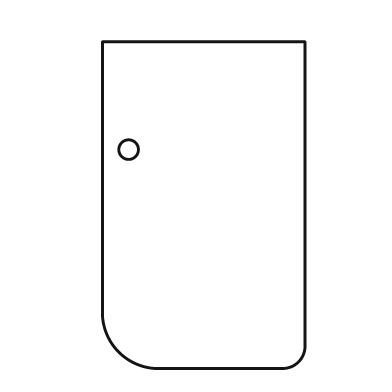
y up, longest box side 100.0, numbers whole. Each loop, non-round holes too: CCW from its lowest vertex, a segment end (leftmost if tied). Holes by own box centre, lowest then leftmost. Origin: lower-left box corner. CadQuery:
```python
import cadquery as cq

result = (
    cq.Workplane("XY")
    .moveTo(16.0, 0.0)
    .lineTo(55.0, 0.0)
    .threePointArc((60.0, 2.0), (62.0, 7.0))
    .lineTo(62.0, 100.0)
    .lineTo(0.0, 100.0)
    .lineTo(0.0, 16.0)
    .threePointArc((5.0, 5.0), (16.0, 0.0))
    .close()
    .moveTo(8.0, 67.0)
    .circle(3.0)
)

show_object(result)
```